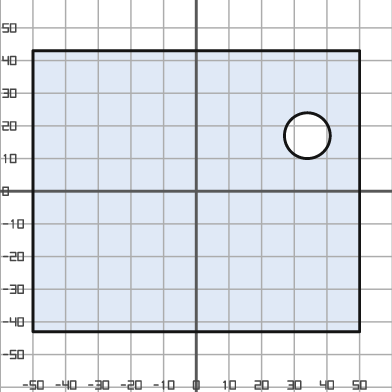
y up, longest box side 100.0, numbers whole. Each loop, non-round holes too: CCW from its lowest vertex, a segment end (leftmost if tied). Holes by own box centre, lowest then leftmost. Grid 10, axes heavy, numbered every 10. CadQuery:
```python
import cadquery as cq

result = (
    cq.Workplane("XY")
    .moveTo(-50.0, -43.0)
    .lineTo(50.0, -43.0)
    .lineTo(50.0, 43.0)
    .lineTo(-50.0, 43.0)
    .close()
    .moveTo(34.0, 17.0)
    .circle(7.0)
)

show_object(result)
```